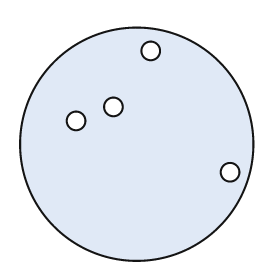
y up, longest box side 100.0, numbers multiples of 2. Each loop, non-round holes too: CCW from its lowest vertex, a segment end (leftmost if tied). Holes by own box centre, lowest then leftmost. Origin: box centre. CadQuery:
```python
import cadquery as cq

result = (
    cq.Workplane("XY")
    .moveTo(0.0, 0.0)
    .circle(50.0)
    .moveTo(40.0, -12.0)
    .circle(4.0)
    .moveTo(-26.0, 10.0)
    .circle(4.0)
    .moveTo(-10.0, 16.0)
    .circle(4.0)
    .moveTo(6.0, 40.0)
    .circle(4.0)
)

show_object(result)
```